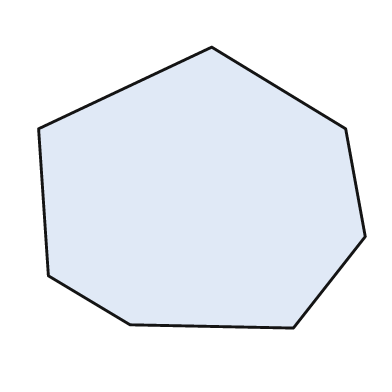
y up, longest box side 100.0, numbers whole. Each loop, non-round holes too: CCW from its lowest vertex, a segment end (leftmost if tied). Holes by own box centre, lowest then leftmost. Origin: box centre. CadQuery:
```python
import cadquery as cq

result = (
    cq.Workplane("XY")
    .moveTo(28.0, -43.0)
    .lineTo(50.0, -15.0)
    .lineTo(44.0, 18.0)
    .lineTo(3.0, 43.0)
    .lineTo(-50.0, 18.0)
    .lineTo(-47.0, -27.0)
    .lineTo(-22.0, -42.0)
    .close()
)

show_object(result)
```